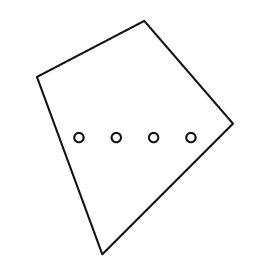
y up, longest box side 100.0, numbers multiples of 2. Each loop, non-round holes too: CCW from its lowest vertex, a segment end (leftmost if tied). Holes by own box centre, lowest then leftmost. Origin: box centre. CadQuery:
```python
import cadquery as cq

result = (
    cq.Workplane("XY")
    .moveTo(-14.0, -50.0)
    .lineTo(42.0, 6.0)
    .lineTo(4.0, 50.0)
    .lineTo(-42.0, 26.0)
    .close()
    .moveTo(-24.0, 0.0)
    .circle(2.0)
    .moveTo(-8.0, 0.0)
    .circle(2.0)
    .moveTo(8.0, 0.0)
    .circle(2.0)
    .moveTo(24.0, 0.0)
    .circle(2.0)
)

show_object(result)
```